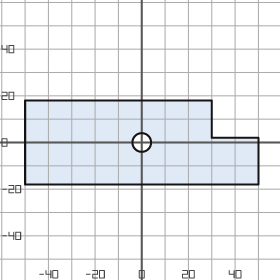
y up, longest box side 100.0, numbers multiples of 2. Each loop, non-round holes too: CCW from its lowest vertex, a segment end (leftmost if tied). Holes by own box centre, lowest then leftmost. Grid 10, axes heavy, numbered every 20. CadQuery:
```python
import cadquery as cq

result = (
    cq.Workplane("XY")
    .moveTo(-50.0, -18.0)
    .lineTo(50.0, -18.0)
    .lineTo(50.0, 2.0)
    .lineTo(30.0, 2.0)
    .lineTo(30.0, 18.0)
    .lineTo(-50.0, 18.0)
    .close()
    .moveTo(0.0, 0.0)
    .circle(4.0)
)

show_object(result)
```